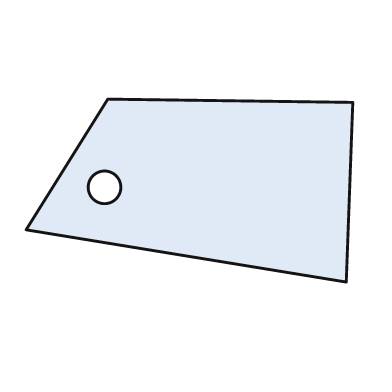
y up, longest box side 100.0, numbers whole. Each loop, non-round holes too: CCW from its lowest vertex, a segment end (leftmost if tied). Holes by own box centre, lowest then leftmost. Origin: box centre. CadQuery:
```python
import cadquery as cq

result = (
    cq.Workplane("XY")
    .moveTo(48.0, -28.0)
    .lineTo(50.0, 27.0)
    .lineTo(-25.0, 28.0)
    .lineTo(-50.0, -12.0)
    .close()
    .moveTo(-26.0, 1.0)
    .circle(5.0)
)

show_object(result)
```